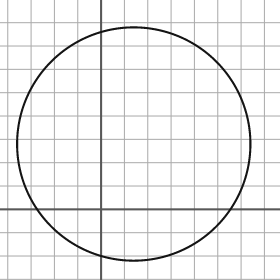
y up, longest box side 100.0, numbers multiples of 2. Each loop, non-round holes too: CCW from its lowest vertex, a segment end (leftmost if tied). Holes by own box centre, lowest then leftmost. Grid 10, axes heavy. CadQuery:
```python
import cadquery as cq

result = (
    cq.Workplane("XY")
    .moveTo(14.0, 28.0)
    .circle(50.0)
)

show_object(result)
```